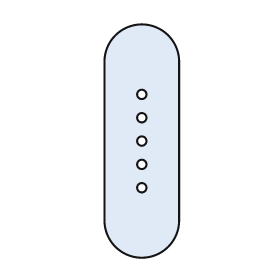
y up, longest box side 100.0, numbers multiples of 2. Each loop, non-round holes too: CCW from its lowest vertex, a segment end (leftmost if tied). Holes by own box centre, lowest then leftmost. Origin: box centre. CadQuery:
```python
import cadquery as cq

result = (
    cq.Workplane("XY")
    .moveTo(-16.0, -34.0)
    .threePointArc((0.0, -50.0), (16.0, -34.0))
    .lineTo(16.0, 34.0)
    .threePointArc((0.0, 50.0), (-16.0, 34.0))
    .close()
    .moveTo(0.0, -20.0)
    .circle(2.0)
    .moveTo(0.0, -10.0)
    .circle(2.0)
    .moveTo(0.0, 0.0)
    .circle(2.0)
    .moveTo(0.0, 10.0)
    .circle(2.0)
    .moveTo(0.0, 20.0)
    .circle(2.0)
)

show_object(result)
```